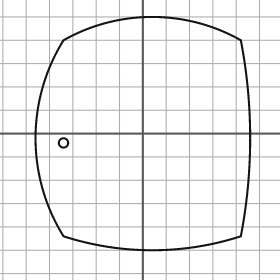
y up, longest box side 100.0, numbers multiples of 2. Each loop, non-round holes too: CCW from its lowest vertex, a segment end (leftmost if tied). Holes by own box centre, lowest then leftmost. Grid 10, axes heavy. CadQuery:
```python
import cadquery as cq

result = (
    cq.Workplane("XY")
    .moveTo(-34.0, -44.0)
    .threePointArc((4.0, -50.0), (42.0, -44.0))
    .threePointArc((46.0, -2.0), (42.0, 40.0))
    .threePointArc((4.0, 50.0), (-34.0, 40.0))
    .threePointArc((-46.0, -2.0), (-34.0, -44.0))
    .close()
    .moveTo(-34.0, -4.0)
    .circle(2.0)
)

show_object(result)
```